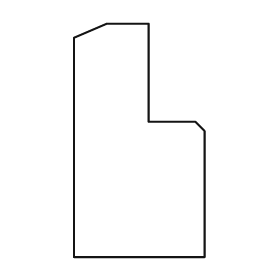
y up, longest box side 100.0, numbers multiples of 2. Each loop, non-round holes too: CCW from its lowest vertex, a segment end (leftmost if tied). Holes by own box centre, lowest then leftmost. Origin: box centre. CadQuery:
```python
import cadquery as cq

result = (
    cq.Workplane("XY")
    .moveTo(-28.0, -50.0)
    .lineTo(28.0, -50.0)
    .lineTo(28.0, 4.0)
    .lineTo(24.0, 8.0)
    .lineTo(4.0, 8.0)
    .lineTo(4.0, 50.0)
    .lineTo(-14.0, 50.0)
    .lineTo(-28.0, 44.0)
    .close()
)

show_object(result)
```